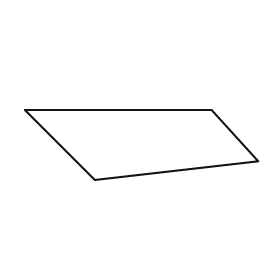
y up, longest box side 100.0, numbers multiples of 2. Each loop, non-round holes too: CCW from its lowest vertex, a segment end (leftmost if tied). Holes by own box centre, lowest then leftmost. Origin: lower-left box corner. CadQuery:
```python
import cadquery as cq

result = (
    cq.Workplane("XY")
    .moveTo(30.0, 0.0)
    .lineTo(100.0, 8.0)
    .lineTo(80.0, 30.0)
    .lineTo(0.0, 30.0)
    .close()
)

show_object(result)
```